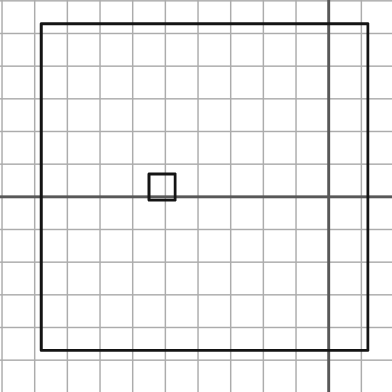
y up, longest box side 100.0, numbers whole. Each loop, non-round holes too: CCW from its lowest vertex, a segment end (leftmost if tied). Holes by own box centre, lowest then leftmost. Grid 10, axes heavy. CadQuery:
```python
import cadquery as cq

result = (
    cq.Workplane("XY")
    .moveTo(-88.0, -47.0)
    .lineTo(12.0, -47.0)
    .lineTo(12.0, 53.0)
    .lineTo(-88.0, 53.0)
    .close()
    .moveTo(-55.0, -1.0)
    .lineTo(-47.0, -1.0)
    .lineTo(-47.0, 7.0)
    .lineTo(-55.0, 7.0)
    .close()
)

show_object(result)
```